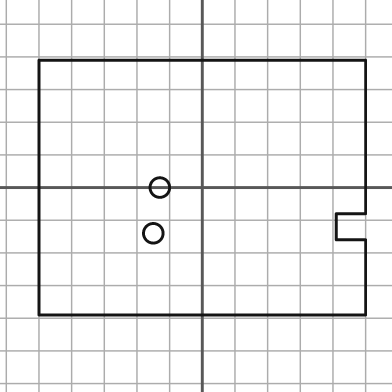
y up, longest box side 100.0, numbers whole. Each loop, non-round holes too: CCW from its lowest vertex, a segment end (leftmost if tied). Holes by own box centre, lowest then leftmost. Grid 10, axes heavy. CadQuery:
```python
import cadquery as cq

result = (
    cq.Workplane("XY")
    .moveTo(-50.0, -39.0)
    .lineTo(50.0, -39.0)
    .lineTo(50.0, -16.0)
    .lineTo(41.0, -16.0)
    .lineTo(41.0, -8.0)
    .lineTo(50.0, -8.0)
    .lineTo(50.0, 39.0)
    .lineTo(-50.0, 39.0)
    .close()
    .moveTo(-15.0, -14.0)
    .circle(3.0)
    .moveTo(-13.0, 0.0)
    .circle(3.0)
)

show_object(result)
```